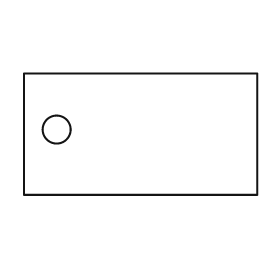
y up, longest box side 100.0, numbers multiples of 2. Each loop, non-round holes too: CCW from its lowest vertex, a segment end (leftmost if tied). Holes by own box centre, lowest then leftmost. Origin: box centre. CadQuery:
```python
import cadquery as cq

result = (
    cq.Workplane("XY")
    .moveTo(-50.0, -26.0)
    .lineTo(50.0, -26.0)
    .lineTo(50.0, 26.0)
    .lineTo(-50.0, 26.0)
    .close()
    .moveTo(-36.0, 2.0)
    .circle(6.0)
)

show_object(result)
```